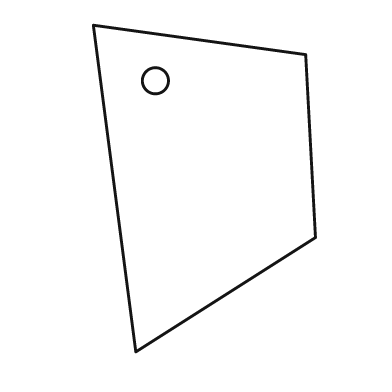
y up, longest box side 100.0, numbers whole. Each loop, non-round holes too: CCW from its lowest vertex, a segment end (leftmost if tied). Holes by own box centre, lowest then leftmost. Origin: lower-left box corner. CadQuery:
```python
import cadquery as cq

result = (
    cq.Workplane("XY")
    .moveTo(13.0, 0.0)
    .lineTo(68.0, 35.0)
    .lineTo(65.0, 91.0)
    .lineTo(0.0, 100.0)
    .close()
    .moveTo(19.0, 83.0)
    .circle(4.0)
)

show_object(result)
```